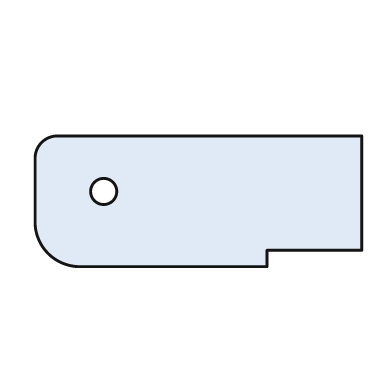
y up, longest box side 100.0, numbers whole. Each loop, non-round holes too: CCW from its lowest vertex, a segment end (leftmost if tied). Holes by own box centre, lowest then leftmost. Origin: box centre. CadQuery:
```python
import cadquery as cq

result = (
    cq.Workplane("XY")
    .moveTo(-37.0, -20.0)
    .lineTo(21.0, -20.0)
    .lineTo(21.0, -15.0)
    .lineTo(50.0, -15.0)
    .lineTo(50.0, 20.0)
    .lineTo(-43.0, 20.0)
    .threePointArc((-48.0, 18.0), (-50.0, 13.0))
    .lineTo(-50.0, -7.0)
    .threePointArc((-46.0, -16.0), (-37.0, -20.0))
    .close()
    .moveTo(-29.0, 3.0)
    .circle(4.0)
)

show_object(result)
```